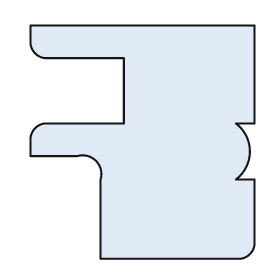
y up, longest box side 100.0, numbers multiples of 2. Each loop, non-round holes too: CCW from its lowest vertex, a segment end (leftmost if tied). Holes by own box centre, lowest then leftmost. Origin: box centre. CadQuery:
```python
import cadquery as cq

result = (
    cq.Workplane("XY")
    .moveTo(-18.0, -50.0)
    .lineTo(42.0, -50.0)
    .threePointArc((46.0, -48.0), (48.0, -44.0))
    .lineTo(48.0, -16.0)
    .lineTo(40.0, -16.0)
    .threePointArc((46.0, -4.0), (40.0, 8.0))
    .lineTo(48.0, 8.0)
    .lineTo(48.0, 50.0)
    .lineTo(-48.0, 50.0)
    .lineTo(-48.0, 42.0)
    .threePointArc((-46.0, 38.0), (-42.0, 36.0))
    .lineTo(-8.0, 36.0)
    .lineTo(-8.0, 8.0)
    .lineTo(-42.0, 8.0)
    .threePointArc((-46.0, 6.0), (-48.0, 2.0))
    .lineTo(-48.0, -6.0)
    .lineTo(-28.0, -6.0)
    .threePointArc((-20.0, -8.0), (-18.0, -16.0))
    .close()
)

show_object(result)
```